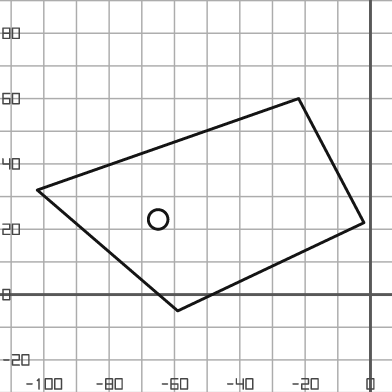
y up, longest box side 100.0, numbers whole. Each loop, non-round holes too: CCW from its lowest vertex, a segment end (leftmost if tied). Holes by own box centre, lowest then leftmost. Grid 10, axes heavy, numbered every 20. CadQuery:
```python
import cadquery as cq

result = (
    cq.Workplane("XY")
    .moveTo(-59.0, -5.0)
    .lineTo(-2.0, 22.0)
    .lineTo(-22.0, 60.0)
    .lineTo(-102.0, 32.0)
    .close()
    .moveTo(-65.0, 23.0)
    .circle(3.0)
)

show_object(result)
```